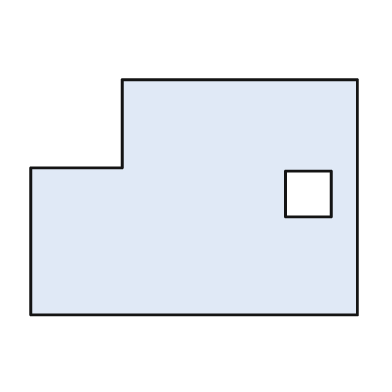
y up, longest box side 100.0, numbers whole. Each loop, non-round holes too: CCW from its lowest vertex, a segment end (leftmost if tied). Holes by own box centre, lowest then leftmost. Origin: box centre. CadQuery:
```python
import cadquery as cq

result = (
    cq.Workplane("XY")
    .moveTo(-50.0, -36.0)
    .lineTo(50.0, -36.0)
    .lineTo(50.0, 36.0)
    .lineTo(-22.0, 36.0)
    .lineTo(-22.0, 9.0)
    .lineTo(-50.0, 9.0)
    .close()
    .moveTo(28.0, -6.0)
    .lineTo(42.0, -6.0)
    .lineTo(42.0, 8.0)
    .lineTo(28.0, 8.0)
    .close()
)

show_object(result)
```